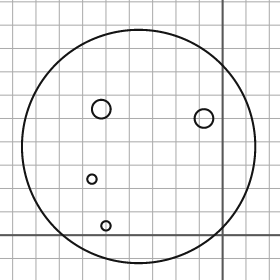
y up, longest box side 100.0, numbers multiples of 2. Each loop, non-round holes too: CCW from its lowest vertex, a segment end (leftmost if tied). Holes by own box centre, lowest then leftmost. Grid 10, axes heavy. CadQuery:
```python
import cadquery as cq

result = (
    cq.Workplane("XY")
    .moveTo(-36.0, 38.0)
    .circle(50.0)
    .moveTo(-50.0, 4.0)
    .circle(2.0)
    .moveTo(-56.0, 24.0)
    .circle(2.0)
    .moveTo(-8.0, 50.0)
    .circle(4.0)
    .moveTo(-52.0, 54.0)
    .circle(4.0)
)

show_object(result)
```